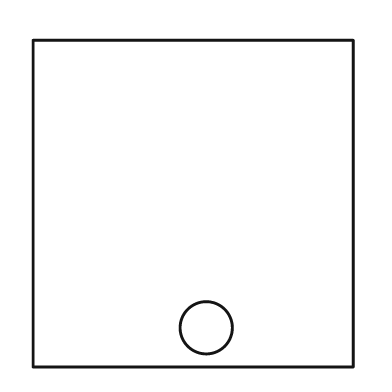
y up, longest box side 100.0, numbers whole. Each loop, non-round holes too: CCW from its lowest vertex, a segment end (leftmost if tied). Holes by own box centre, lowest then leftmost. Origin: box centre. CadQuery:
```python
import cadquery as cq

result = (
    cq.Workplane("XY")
    .moveTo(-49.0, -50.0)
    .lineTo(49.0, -50.0)
    .lineTo(49.0, 50.0)
    .lineTo(-49.0, 50.0)
    .close()
    .moveTo(4.0, -38.0)
    .circle(8.0)
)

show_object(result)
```